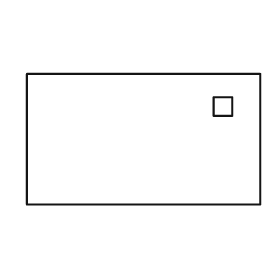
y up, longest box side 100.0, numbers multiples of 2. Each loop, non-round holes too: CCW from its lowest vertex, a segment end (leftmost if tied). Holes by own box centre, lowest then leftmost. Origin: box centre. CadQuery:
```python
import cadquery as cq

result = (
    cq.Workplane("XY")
    .moveTo(-50.0, -28.0)
    .lineTo(50.0, -28.0)
    .lineTo(50.0, 28.0)
    .lineTo(-50.0, 28.0)
    .close()
    .moveTo(30.0, 10.0)
    .lineTo(38.0, 10.0)
    .lineTo(38.0, 18.0)
    .lineTo(30.0, 18.0)
    .close()
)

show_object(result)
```